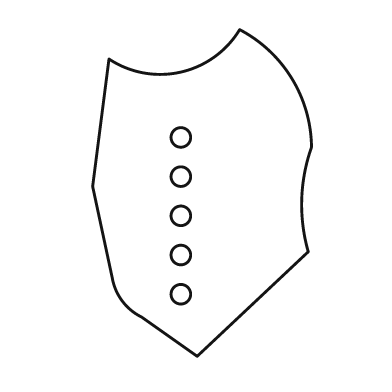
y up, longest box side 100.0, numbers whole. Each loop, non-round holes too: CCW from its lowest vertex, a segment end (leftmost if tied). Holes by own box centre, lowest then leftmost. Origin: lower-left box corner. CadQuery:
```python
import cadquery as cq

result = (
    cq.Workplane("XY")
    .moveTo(32.0, 0.0)
    .lineTo(66.0, 32.0)
    .threePointArc((64.0, 48.0), (67.0, 64.0))
    .threePointArc((61.0, 85.0), (45.0, 100.0))
    .threePointArc((27.0, 87.0), (5.0, 91.0))
    .lineTo(0.0, 52.0)
    .lineTo(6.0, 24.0)
    .threePointArc((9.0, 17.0), (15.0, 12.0))
    .close()
    .moveTo(27.0, 19.0)
    .circle(3.0)
    .moveTo(27.0, 31.0)
    .circle(3.0)
    .moveTo(27.0, 43.0)
    .circle(3.0)
    .moveTo(27.0, 55.0)
    .circle(3.0)
    .moveTo(27.0, 67.0)
    .circle(3.0)
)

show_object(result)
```